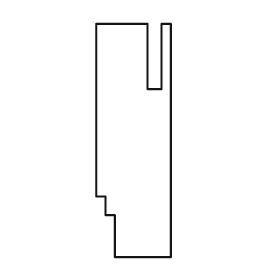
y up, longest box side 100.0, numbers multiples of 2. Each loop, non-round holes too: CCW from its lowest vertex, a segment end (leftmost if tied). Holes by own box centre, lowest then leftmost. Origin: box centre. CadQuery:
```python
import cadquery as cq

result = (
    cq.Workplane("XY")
    .moveTo(-8.0, -50.0)
    .lineTo(16.0, -50.0)
    .lineTo(16.0, 50.0)
    .lineTo(12.0, 50.0)
    .lineTo(12.0, 22.0)
    .lineTo(6.0, 22.0)
    .lineTo(6.0, 50.0)
    .lineTo(-16.0, 50.0)
    .lineTo(-16.0, -24.0)
    .lineTo(-12.0, -24.0)
    .lineTo(-12.0, -32.0)
    .lineTo(-8.0, -32.0)
    .close()
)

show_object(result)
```